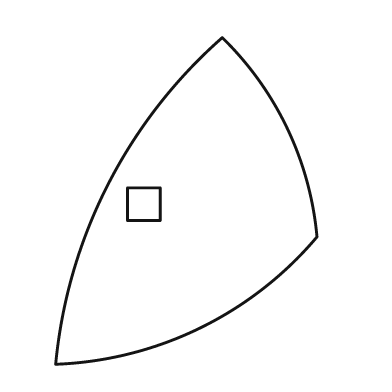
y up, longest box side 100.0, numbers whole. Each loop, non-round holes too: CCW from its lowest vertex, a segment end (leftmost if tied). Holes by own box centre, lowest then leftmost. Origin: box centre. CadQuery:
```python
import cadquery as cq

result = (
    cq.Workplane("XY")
    .moveTo(-40.0, -50.0)
    .threePointArc((4.0, -39.0), (40.0, -11.0))
    .threePointArc((31.0, 22.0), (11.0, 50.0))
    .threePointArc((-24.0, 5.0), (-40.0, -50.0))
    .close()
    .moveTo(-18.0, -6.0)
    .lineTo(-8.0, -6.0)
    .lineTo(-8.0, 4.0)
    .lineTo(-18.0, 4.0)
    .close()
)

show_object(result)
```